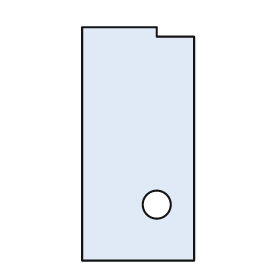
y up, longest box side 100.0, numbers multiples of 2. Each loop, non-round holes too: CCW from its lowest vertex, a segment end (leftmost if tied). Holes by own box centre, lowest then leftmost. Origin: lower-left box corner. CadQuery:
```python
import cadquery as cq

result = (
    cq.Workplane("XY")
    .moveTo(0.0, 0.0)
    .lineTo(48.0, 0.0)
    .lineTo(48.0, 96.0)
    .lineTo(32.0, 96.0)
    .lineTo(32.0, 100.0)
    .lineTo(0.0, 100.0)
    .close()
    .moveTo(32.0, 24.0)
    .circle(6.0)
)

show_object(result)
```